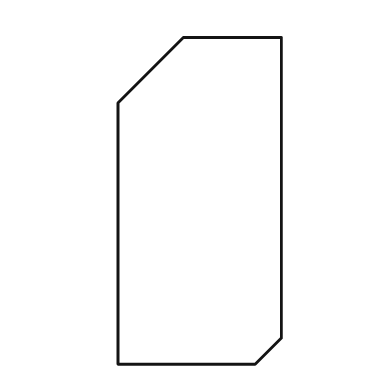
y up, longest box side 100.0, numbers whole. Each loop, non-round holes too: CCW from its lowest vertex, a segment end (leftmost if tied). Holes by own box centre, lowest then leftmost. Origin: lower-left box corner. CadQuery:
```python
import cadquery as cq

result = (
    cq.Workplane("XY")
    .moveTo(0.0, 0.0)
    .lineTo(42.0, 0.0)
    .lineTo(50.0, 8.0)
    .lineTo(50.0, 100.0)
    .lineTo(20.0, 100.0)
    .lineTo(0.0, 80.0)
    .close()
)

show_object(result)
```